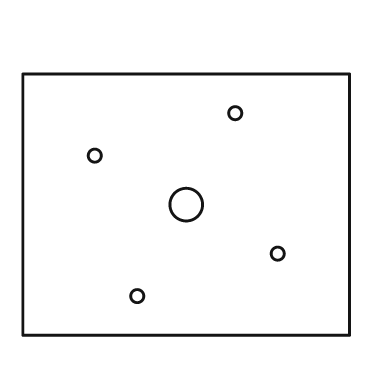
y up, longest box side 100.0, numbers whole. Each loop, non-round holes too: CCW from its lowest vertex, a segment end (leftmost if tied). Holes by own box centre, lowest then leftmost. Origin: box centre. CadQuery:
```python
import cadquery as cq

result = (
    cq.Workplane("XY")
    .moveTo(-50.0, -40.0)
    .lineTo(50.0, -40.0)
    .lineTo(50.0, 40.0)
    .lineTo(-50.0, 40.0)
    .close()
    .moveTo(-15.0, -28.0)
    .circle(2.0)
    .moveTo(28.0, -15.0)
    .circle(2.0)
    .moveTo(0.0, 0.0)
    .circle(5.0)
    .moveTo(-28.0, 15.0)
    .circle(2.0)
    .moveTo(15.0, 28.0)
    .circle(2.0)
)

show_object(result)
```